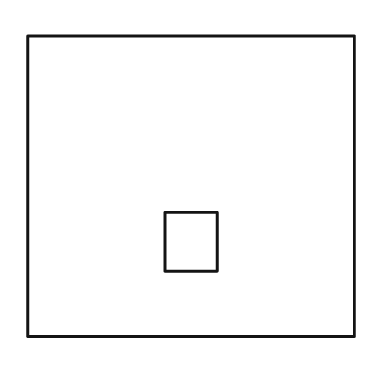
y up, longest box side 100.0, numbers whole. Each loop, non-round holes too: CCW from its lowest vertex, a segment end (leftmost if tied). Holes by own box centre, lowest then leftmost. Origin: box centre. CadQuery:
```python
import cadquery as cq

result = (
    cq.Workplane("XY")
    .moveTo(-50.0, -46.0)
    .lineTo(50.0, -46.0)
    .lineTo(50.0, 46.0)
    .lineTo(-50.0, 46.0)
    .close()
    .moveTo(-8.0, -26.0)
    .lineTo(8.0, -26.0)
    .lineTo(8.0, -8.0)
    .lineTo(-8.0, -8.0)
    .close()
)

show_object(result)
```